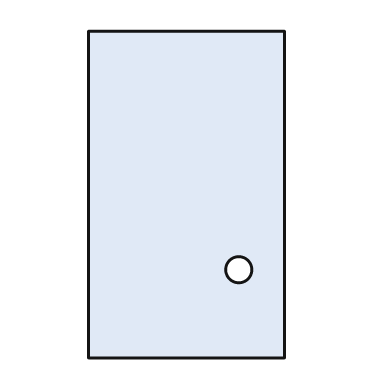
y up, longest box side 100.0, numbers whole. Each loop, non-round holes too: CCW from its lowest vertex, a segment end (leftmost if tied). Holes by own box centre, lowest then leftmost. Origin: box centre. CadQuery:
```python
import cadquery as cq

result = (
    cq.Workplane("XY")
    .moveTo(-30.0, -50.0)
    .lineTo(30.0, -50.0)
    .lineTo(30.0, 50.0)
    .lineTo(-30.0, 50.0)
    .close()
    .moveTo(16.0, -23.0)
    .circle(4.0)
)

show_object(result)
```